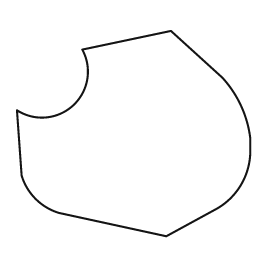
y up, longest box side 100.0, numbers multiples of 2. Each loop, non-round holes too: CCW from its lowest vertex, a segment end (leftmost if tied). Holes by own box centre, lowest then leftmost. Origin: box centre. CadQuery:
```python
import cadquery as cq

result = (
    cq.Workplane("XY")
    .moveTo(14.0, -44.0)
    .lineTo(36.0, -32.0)
    .threePointArc((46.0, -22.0), (50.0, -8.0))
    .lineTo(50.0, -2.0)
    .threePointArc((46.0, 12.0), (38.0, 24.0))
    .lineTo(16.0, 44.0)
    .lineTo(-22.0, 36.0)
    .threePointArc((-26.0, 12.0), (-50.0, 10.0))
    .lineTo(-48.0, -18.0)
    .threePointArc((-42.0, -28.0), (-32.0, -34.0))
    .close()
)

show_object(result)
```